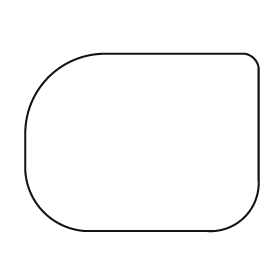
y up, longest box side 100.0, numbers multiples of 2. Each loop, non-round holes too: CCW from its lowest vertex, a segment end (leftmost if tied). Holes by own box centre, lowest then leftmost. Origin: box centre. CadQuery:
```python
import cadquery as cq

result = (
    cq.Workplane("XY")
    .moveTo(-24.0, -38.0)
    .lineTo(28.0, -38.0)
    .threePointArc((44.0, -32.0), (50.0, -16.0))
    .lineTo(50.0, 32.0)
    .threePointArc((48.0, 36.0), (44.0, 38.0))
    .lineTo(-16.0, 38.0)
    .threePointArc((-40.0, 28.0), (-50.0, 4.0))
    .lineTo(-50.0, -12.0)
    .threePointArc((-42.0, -30.0), (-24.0, -38.0))
    .close()
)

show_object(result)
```